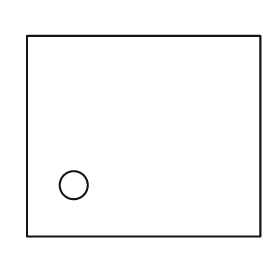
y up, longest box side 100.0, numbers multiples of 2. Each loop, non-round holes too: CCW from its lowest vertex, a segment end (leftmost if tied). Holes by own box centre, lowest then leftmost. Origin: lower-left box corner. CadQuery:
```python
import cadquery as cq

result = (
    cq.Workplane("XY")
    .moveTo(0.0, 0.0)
    .lineTo(100.0, 0.0)
    .lineTo(100.0, 86.0)
    .lineTo(0.0, 86.0)
    .close()
    .moveTo(20.0, 22.0)
    .circle(6.0)
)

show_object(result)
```